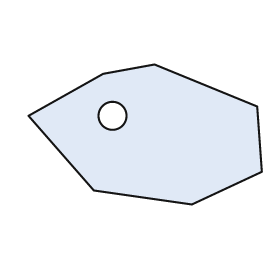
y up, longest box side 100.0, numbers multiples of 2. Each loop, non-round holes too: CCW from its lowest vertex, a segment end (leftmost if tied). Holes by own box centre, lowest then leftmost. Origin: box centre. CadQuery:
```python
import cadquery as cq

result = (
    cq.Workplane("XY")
    .moveTo(20.0, -30.0)
    .lineTo(50.0, -16.0)
    .lineTo(48.0, 12.0)
    .lineTo(4.0, 30.0)
    .lineTo(-18.0, 26.0)
    .lineTo(-50.0, 8.0)
    .lineTo(-22.0, -24.0)
    .close()
    .moveTo(-14.0, 8.0)
    .circle(6.0)
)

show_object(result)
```